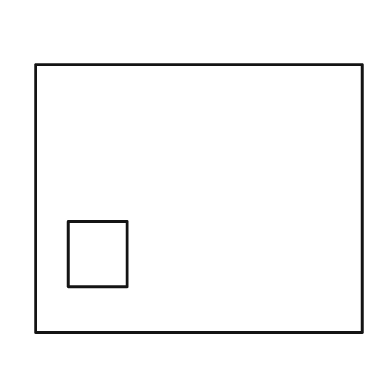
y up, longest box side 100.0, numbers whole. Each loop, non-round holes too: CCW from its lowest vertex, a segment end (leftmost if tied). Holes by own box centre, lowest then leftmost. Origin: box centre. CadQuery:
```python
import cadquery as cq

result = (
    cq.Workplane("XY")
    .moveTo(-50.0, -41.0)
    .lineTo(50.0, -41.0)
    .lineTo(50.0, 41.0)
    .lineTo(-50.0, 41.0)
    .close()
    .moveTo(-40.0, -27.0)
    .lineTo(-22.0, -27.0)
    .lineTo(-22.0, -7.0)
    .lineTo(-40.0, -7.0)
    .close()
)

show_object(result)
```